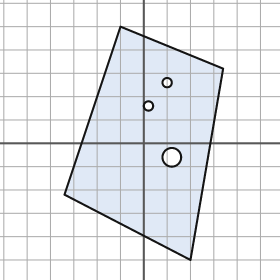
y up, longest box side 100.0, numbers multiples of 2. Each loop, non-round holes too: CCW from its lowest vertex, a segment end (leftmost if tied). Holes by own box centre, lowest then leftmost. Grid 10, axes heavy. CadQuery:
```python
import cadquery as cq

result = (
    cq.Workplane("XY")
    .moveTo(20.0, -50.0)
    .lineTo(34.0, 32.0)
    .lineTo(-10.0, 50.0)
    .lineTo(-34.0, -22.0)
    .close()
    .moveTo(12.0, -6.0)
    .circle(4.0)
    .moveTo(2.0, 16.0)
    .circle(2.0)
    .moveTo(10.0, 26.0)
    .circle(2.0)
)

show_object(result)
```